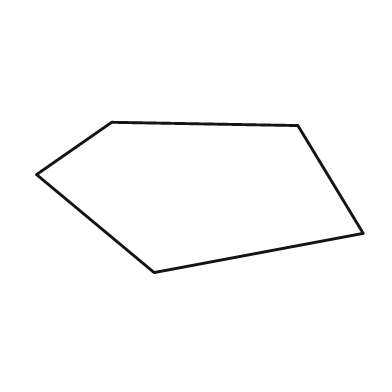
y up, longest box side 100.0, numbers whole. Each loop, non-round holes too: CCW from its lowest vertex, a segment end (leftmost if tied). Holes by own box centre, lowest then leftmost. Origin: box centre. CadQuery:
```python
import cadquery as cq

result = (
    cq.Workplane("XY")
    .moveTo(-14.0, -23.0)
    .lineTo(50.0, -11.0)
    .lineTo(30.0, 22.0)
    .lineTo(-27.0, 23.0)
    .lineTo(-50.0, 7.0)
    .close()
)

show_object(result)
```